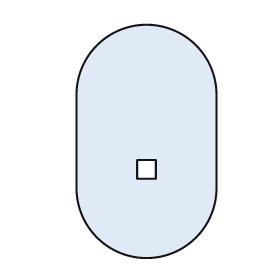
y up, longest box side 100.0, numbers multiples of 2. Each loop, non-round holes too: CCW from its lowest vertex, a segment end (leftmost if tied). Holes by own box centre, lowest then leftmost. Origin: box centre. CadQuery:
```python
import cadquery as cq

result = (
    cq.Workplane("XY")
    .moveTo(-30.0, -20.0)
    .threePointArc((0.0, -50.0), (30.0, -20.0))
    .lineTo(30.0, 20.0)
    .threePointArc((0.0, 50.0), (-30.0, 20.0))
    .close()
    .moveTo(-4.0, -16.0)
    .lineTo(4.0, -16.0)
    .lineTo(4.0, -8.0)
    .lineTo(-4.0, -8.0)
    .close()
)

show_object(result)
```